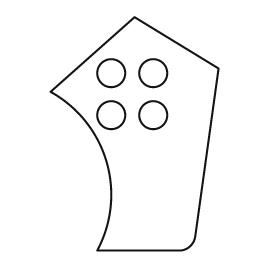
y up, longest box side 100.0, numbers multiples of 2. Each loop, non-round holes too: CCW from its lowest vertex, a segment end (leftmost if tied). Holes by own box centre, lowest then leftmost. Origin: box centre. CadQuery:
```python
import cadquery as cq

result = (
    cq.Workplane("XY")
    .moveTo(-16.0, -50.0)
    .lineTo(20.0, -50.0)
    .threePointArc((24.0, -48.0), (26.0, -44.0))
    .lineTo(36.0, 28.0)
    .lineTo(0.0, 50.0)
    .lineTo(-36.0, 18.0)
    .threePointArc((-12.0, -12.0), (-16.0, -50.0))
    .close()
    .moveTo(-10.0, 8.0)
    .circle(6.0)
    .moveTo(8.0, 8.0)
    .circle(6.0)
    .moveTo(-10.0, 26.0)
    .circle(6.0)
    .moveTo(8.0, 26.0)
    .circle(6.0)
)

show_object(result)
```